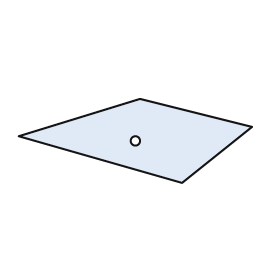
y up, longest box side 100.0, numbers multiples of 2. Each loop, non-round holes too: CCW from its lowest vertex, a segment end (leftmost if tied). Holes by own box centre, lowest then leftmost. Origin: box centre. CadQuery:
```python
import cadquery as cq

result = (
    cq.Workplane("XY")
    .moveTo(20.0, -18.0)
    .lineTo(50.0, 6.0)
    .lineTo(2.0, 18.0)
    .lineTo(-50.0, 2.0)
    .close()
    .moveTo(0.0, 0.0)
    .circle(2.0)
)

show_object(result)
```